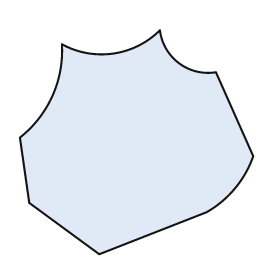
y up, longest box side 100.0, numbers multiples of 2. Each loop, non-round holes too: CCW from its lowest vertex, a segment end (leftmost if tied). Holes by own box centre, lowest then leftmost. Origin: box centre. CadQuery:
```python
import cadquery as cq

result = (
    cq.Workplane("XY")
    .moveTo(-16.0, -48.0)
    .lineTo(30.0, -30.0)
    .threePointArc((42.0, -20.0), (50.0, -6.0))
    .lineTo(34.0, 30.0)
    .threePointArc((18.0, 34.0), (10.0, 48.0))
    .threePointArc((-10.0, 38.0), (-32.0, 42.0))
    .threePointArc((-36.0, 20.0), (-50.0, 2.0))
    .lineTo(-46.0, -26.0)
    .close()
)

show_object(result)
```